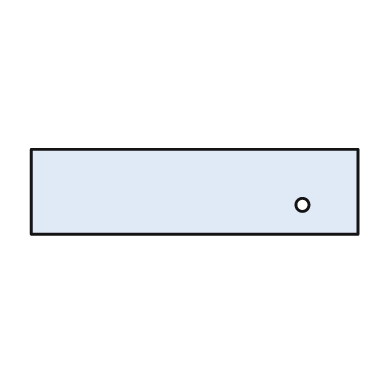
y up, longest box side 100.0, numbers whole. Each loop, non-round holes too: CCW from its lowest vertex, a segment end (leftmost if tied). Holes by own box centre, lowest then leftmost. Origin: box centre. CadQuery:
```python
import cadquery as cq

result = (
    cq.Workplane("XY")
    .moveTo(-50.0, -13.0)
    .lineTo(50.0, -13.0)
    .lineTo(50.0, 13.0)
    .lineTo(-50.0, 13.0)
    .close()
    .moveTo(33.0, -4.0)
    .circle(2.0)
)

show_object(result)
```